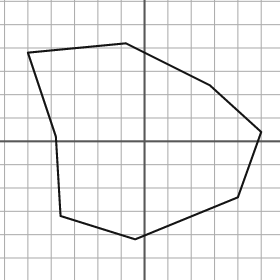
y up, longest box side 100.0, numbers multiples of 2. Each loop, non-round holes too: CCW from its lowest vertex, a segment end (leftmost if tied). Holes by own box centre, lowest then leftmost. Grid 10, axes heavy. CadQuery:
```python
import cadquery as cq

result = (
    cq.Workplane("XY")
    .moveTo(-4.0, -42.0)
    .lineTo(40.0, -24.0)
    .lineTo(50.0, 4.0)
    .lineTo(28.0, 24.0)
    .lineTo(-8.0, 42.0)
    .lineTo(-50.0, 38.0)
    .lineTo(-38.0, 2.0)
    .lineTo(-36.0, -32.0)
    .close()
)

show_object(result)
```